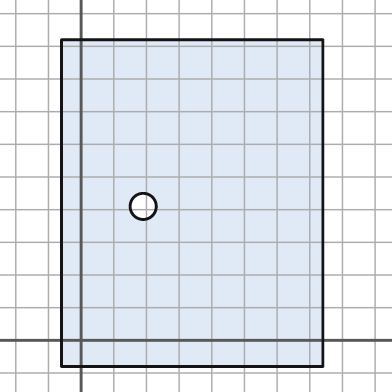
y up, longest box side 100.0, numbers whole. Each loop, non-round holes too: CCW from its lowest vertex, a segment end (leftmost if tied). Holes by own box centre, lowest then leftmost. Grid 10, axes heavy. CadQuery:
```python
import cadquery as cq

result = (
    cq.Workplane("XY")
    .moveTo(-6.0, -8.0)
    .lineTo(74.0, -8.0)
    .lineTo(74.0, 92.0)
    .lineTo(-6.0, 92.0)
    .close()
    .moveTo(19.0, 41.0)
    .circle(4.0)
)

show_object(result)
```